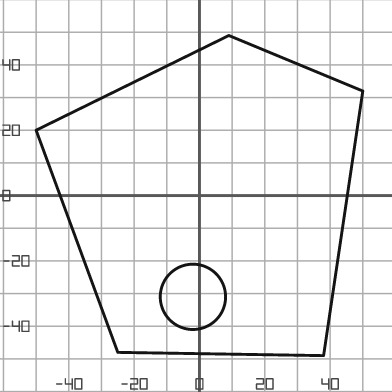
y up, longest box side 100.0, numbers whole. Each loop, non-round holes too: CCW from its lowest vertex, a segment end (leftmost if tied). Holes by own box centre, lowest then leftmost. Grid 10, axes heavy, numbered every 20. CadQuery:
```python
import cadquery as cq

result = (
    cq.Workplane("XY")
    .moveTo(38.0, -49.0)
    .lineTo(50.0, 32.0)
    .lineTo(9.0, 49.0)
    .lineTo(-50.0, 20.0)
    .lineTo(-25.0, -48.0)
    .close()
    .moveTo(-2.0, -31.0)
    .circle(10.0)
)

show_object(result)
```